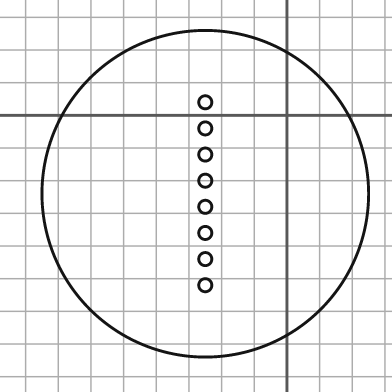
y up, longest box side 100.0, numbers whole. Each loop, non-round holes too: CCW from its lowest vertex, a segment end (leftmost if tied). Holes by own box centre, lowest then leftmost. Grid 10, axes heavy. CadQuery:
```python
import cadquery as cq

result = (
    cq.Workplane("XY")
    .moveTo(-25.0, -24.0)
    .circle(50.0)
    .moveTo(-25.0, -52.0)
    .circle(2.0)
    .moveTo(-25.0, -44.0)
    .circle(2.0)
    .moveTo(-25.0, -36.0)
    .circle(2.0)
    .moveTo(-25.0, -28.0)
    .circle(2.0)
    .moveTo(-25.0, -20.0)
    .circle(2.0)
    .moveTo(-25.0, -12.0)
    .circle(2.0)
    .moveTo(-25.0, -4.0)
    .circle(2.0)
    .moveTo(-25.0, 4.0)
    .circle(2.0)
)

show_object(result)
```